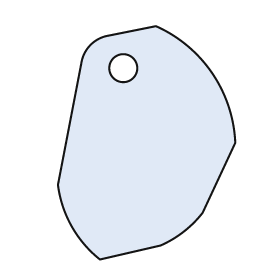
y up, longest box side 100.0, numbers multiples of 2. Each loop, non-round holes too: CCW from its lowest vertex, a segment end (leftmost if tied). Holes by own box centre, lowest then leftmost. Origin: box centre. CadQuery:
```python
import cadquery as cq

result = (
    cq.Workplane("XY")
    .moveTo(-20.0, -50.0)
    .lineTo(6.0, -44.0)
    .threePointArc((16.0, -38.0), (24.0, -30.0))
    .lineTo(38.0, 0.0)
    .threePointArc((28.0, 30.0), (4.0, 50.0))
    .lineTo(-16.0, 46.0)
    .threePointArc((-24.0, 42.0), (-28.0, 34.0))
    .lineTo(-38.0, -18.0)
    .threePointArc((-32.0, -36.0), (-20.0, -50.0))
    .close()
    .moveTo(-10.0, 32.0)
    .circle(6.0)
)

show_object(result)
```